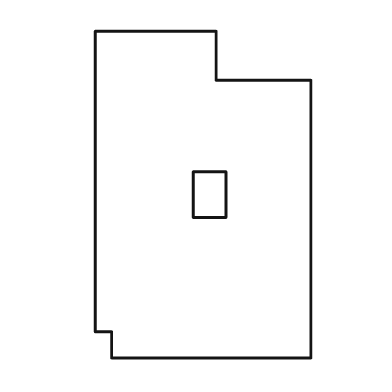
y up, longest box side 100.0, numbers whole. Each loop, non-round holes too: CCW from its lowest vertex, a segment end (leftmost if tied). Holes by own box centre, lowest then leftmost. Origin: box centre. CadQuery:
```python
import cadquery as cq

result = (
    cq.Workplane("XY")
    .moveTo(-28.0, -50.0)
    .lineTo(33.0, -50.0)
    .lineTo(33.0, 35.0)
    .lineTo(4.0, 35.0)
    .lineTo(4.0, 50.0)
    .lineTo(-33.0, 50.0)
    .lineTo(-33.0, -42.0)
    .lineTo(-28.0, -42.0)
    .close()
    .moveTo(-3.0, -7.0)
    .lineTo(7.0, -7.0)
    .lineTo(7.0, 7.0)
    .lineTo(-3.0, 7.0)
    .close()
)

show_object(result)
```